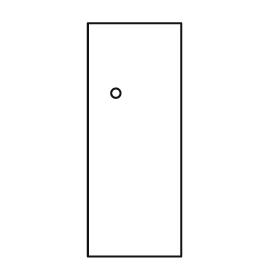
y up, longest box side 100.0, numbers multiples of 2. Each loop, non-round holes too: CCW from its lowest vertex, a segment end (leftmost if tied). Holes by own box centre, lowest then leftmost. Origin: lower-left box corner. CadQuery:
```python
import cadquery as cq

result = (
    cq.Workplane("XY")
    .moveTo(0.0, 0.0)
    .lineTo(40.0, 0.0)
    .lineTo(40.0, 100.0)
    .lineTo(0.0, 100.0)
    .close()
    .moveTo(12.0, 70.0)
    .circle(2.0)
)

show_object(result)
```